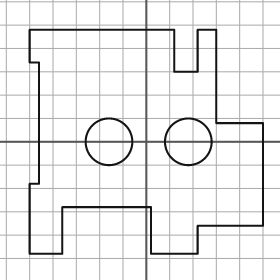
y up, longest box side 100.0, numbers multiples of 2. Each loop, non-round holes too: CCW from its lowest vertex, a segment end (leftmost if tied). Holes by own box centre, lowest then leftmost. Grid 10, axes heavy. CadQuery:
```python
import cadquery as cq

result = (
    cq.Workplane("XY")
    .moveTo(-50.0, -48.0)
    .lineTo(-36.0, -48.0)
    .lineTo(-36.0, -28.0)
    .lineTo(2.0, -28.0)
    .lineTo(2.0, -48.0)
    .lineTo(22.0, -48.0)
    .lineTo(22.0, -36.0)
    .lineTo(50.0, -36.0)
    .lineTo(50.0, 8.0)
    .lineTo(30.0, 8.0)
    .lineTo(30.0, 48.0)
    .lineTo(22.0, 48.0)
    .lineTo(22.0, 30.0)
    .lineTo(12.0, 30.0)
    .lineTo(12.0, 48.0)
    .lineTo(-50.0, 48.0)
    .lineTo(-50.0, 34.0)
    .lineTo(-46.0, 34.0)
    .lineTo(-46.0, -18.0)
    .lineTo(-50.0, -18.0)
    .close()
    .moveTo(-16.0, 0.0)
    .circle(10.0)
    .moveTo(18.0, 0.0)
    .circle(10.0)
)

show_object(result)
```